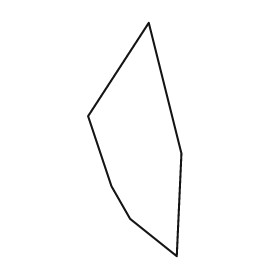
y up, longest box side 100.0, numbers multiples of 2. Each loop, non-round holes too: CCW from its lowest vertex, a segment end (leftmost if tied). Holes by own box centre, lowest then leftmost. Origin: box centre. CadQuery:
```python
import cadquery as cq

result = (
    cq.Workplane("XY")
    .moveTo(18.0, -50.0)
    .lineTo(20.0, -6.0)
    .lineTo(6.0, 50.0)
    .lineTo(-20.0, 10.0)
    .lineTo(-10.0, -20.0)
    .lineTo(-2.0, -34.0)
    .close()
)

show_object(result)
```